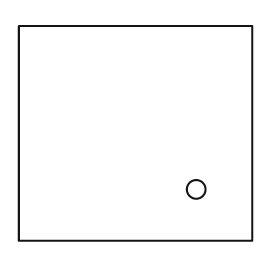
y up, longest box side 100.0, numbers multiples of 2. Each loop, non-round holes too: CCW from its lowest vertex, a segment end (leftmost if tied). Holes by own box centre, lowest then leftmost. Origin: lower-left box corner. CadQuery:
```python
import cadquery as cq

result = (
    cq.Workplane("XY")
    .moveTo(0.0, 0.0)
    .lineTo(100.0, 0.0)
    .lineTo(100.0, 92.0)
    .lineTo(0.0, 92.0)
    .close()
    .moveTo(76.0, 22.0)
    .circle(4.0)
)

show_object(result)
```